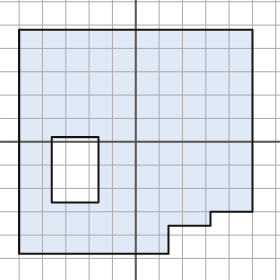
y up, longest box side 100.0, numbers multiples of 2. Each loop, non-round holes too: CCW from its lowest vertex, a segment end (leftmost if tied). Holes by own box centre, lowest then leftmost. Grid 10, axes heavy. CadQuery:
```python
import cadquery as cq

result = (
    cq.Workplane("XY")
    .moveTo(-50.0, -48.0)
    .lineTo(14.0, -48.0)
    .lineTo(14.0, -36.0)
    .lineTo(32.0, -36.0)
    .lineTo(32.0, -30.0)
    .lineTo(50.0, -30.0)
    .lineTo(50.0, 48.0)
    .lineTo(-50.0, 48.0)
    .close()
    .moveTo(-36.0, -26.0)
    .lineTo(-16.0, -26.0)
    .lineTo(-16.0, 2.0)
    .lineTo(-36.0, 2.0)
    .close()
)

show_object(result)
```